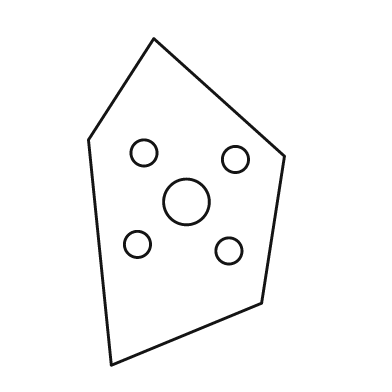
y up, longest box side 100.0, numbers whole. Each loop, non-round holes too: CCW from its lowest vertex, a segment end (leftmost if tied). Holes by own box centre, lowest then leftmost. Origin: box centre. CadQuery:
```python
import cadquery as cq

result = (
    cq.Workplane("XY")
    .moveTo(-23.0, -50.0)
    .lineTo(23.0, -31.0)
    .lineTo(30.0, 14.0)
    .lineTo(-10.0, 50.0)
    .lineTo(-30.0, 19.0)
    .close()
    .moveTo(13.0, -15.0)
    .circle(4.0)
    .moveTo(-15.0, -13.0)
    .circle(4.0)
    .moveTo(0.0, 0.0)
    .circle(7.0)
    .moveTo(15.0, 13.0)
    .circle(4.0)
    .moveTo(-13.0, 15.0)
    .circle(4.0)
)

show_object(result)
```